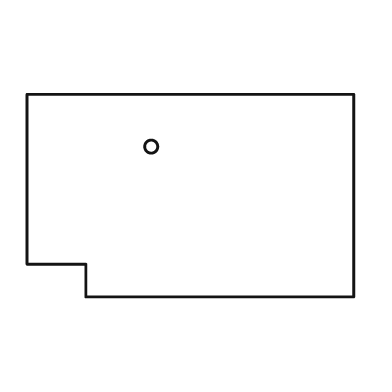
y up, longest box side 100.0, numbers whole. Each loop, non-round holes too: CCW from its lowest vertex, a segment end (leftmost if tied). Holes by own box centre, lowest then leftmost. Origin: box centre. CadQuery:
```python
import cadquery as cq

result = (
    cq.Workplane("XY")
    .moveTo(-32.0, -31.0)
    .lineTo(50.0, -31.0)
    .lineTo(50.0, 31.0)
    .lineTo(-50.0, 31.0)
    .lineTo(-50.0, -21.0)
    .lineTo(-32.0, -21.0)
    .close()
    .moveTo(-12.0, 15.0)
    .circle(2.0)
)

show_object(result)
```